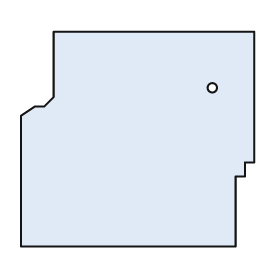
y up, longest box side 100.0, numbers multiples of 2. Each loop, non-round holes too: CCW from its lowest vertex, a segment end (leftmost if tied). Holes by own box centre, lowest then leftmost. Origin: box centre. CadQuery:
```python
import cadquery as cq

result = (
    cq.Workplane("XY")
    .moveTo(-50.0, -46.0)
    .lineTo(42.0, -46.0)
    .lineTo(42.0, -16.0)
    .lineTo(46.0, -16.0)
    .lineTo(46.0, -10.0)
    .lineTo(50.0, -10.0)
    .lineTo(50.0, 46.0)
    .lineTo(-36.0, 46.0)
    .lineTo(-36.0, 18.0)
    .lineTo(-40.0, 14.0)
    .lineTo(-44.0, 14.0)
    .lineTo(-50.0, 10.0)
    .close()
    .moveTo(32.0, 22.0)
    .circle(2.0)
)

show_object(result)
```